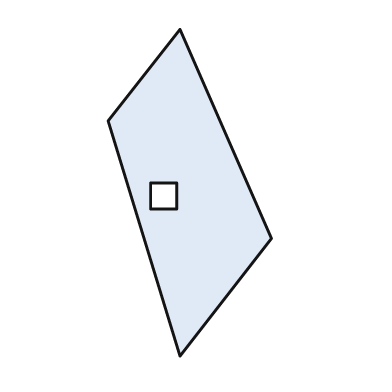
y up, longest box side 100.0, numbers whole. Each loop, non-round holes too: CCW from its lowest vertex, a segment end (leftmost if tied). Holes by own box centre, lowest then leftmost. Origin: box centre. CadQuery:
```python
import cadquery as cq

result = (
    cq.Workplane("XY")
    .moveTo(-3.0, -50.0)
    .lineTo(25.0, -14.0)
    .lineTo(-3.0, 50.0)
    .lineTo(-25.0, 22.0)
    .close()
    .moveTo(-12.0, -5.0)
    .lineTo(-4.0, -5.0)
    .lineTo(-4.0, 3.0)
    .lineTo(-12.0, 3.0)
    .close()
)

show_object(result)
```